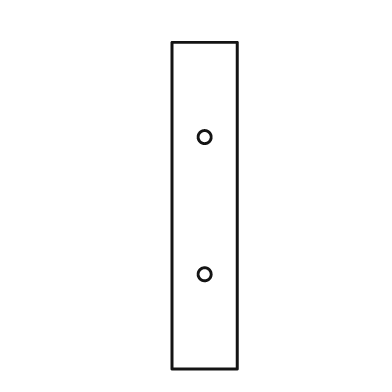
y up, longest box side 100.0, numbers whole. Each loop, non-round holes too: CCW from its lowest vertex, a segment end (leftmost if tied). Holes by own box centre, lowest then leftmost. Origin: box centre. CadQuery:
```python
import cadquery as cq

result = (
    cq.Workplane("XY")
    .moveTo(-10.0, -50.0)
    .lineTo(10.0, -50.0)
    .lineTo(10.0, 50.0)
    .lineTo(-10.0, 50.0)
    .close()
    .moveTo(0.0, -21.0)
    .circle(2.0)
    .moveTo(0.0, 21.0)
    .circle(2.0)
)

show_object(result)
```